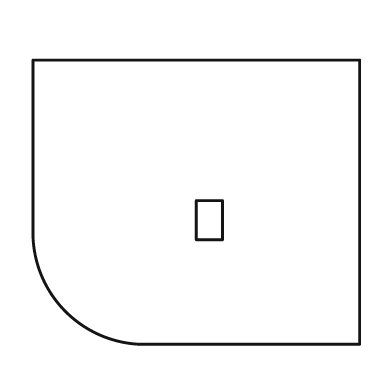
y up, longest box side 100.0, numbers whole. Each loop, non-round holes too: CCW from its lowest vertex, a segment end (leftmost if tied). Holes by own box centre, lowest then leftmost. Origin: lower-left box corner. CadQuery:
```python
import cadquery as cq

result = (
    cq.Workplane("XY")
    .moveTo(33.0, 0.0)
    .lineTo(100.0, 0.0)
    .lineTo(100.0, 87.0)
    .lineTo(0.0, 87.0)
    .lineTo(0.0, 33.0)
    .threePointArc((10.0, 10.0), (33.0, 0.0))
    .close()
    .moveTo(50.0, 32.0)
    .lineTo(58.0, 32.0)
    .lineTo(58.0, 44.0)
    .lineTo(50.0, 44.0)
    .close()
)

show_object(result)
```